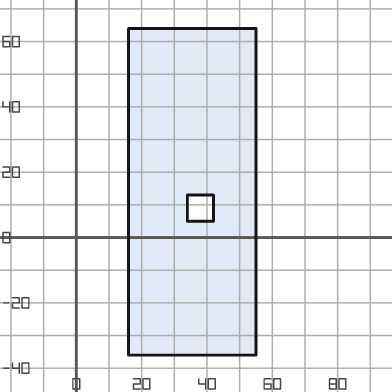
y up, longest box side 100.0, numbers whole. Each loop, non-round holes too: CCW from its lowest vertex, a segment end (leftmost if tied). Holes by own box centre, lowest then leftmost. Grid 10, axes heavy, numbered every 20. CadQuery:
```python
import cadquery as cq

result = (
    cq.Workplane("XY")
    .moveTo(16.0, -36.0)
    .lineTo(55.0, -36.0)
    .lineTo(55.0, 64.0)
    .lineTo(16.0, 64.0)
    .close()
    .moveTo(34.0, 5.0)
    .lineTo(42.0, 5.0)
    .lineTo(42.0, 13.0)
    .lineTo(34.0, 13.0)
    .close()
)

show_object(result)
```